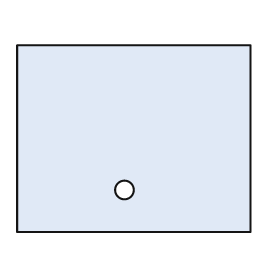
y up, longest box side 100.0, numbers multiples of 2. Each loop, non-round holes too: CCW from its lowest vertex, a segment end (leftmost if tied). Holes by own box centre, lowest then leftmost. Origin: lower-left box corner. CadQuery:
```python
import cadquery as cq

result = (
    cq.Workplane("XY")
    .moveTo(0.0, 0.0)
    .lineTo(100.0, 0.0)
    .lineTo(100.0, 80.0)
    .lineTo(0.0, 80.0)
    .close()
    .moveTo(46.0, 18.0)
    .circle(4.0)
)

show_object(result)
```